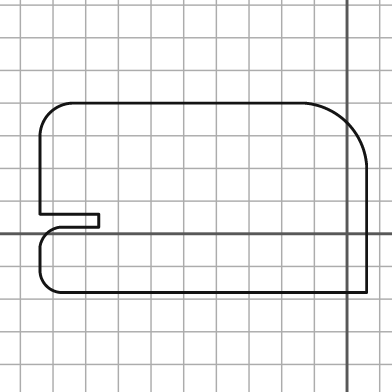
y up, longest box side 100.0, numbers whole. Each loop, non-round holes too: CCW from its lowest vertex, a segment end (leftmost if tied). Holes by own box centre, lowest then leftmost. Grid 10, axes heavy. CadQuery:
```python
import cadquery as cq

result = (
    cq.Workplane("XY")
    .moveTo(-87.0, -18.0)
    .lineTo(6.0, -18.0)
    .lineTo(6.0, 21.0)
    .threePointArc((0.0, 34.0), (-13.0, 40.0))
    .lineTo(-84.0, 40.0)
    .threePointArc((-91.0, 37.0), (-94.0, 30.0))
    .lineTo(-94.0, 6.0)
    .lineTo(-76.0, 6.0)
    .lineTo(-76.0, 2.0)
    .lineTo(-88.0, 2.0)
    .threePointArc((-92.0, 0.0), (-94.0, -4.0))
    .lineTo(-94.0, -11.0)
    .threePointArc((-92.0, -16.0), (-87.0, -18.0))
    .close()
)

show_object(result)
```